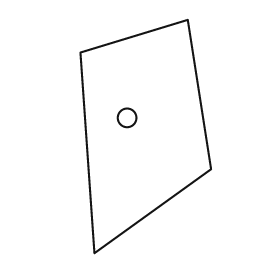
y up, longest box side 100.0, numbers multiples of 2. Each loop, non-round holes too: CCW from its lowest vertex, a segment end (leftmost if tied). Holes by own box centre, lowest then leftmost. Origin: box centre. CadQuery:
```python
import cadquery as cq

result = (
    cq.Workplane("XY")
    .moveTo(-22.0, -50.0)
    .lineTo(28.0, -14.0)
    .lineTo(18.0, 50.0)
    .lineTo(-28.0, 36.0)
    .close()
    .moveTo(-8.0, 8.0)
    .circle(4.0)
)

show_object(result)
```